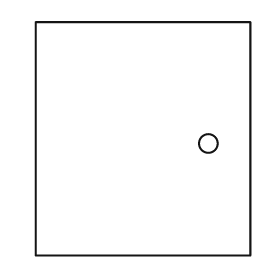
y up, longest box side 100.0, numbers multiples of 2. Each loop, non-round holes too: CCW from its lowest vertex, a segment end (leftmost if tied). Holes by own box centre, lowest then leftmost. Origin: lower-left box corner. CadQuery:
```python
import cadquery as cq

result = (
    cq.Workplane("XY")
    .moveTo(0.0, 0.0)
    .lineTo(92.0, 0.0)
    .lineTo(92.0, 100.0)
    .lineTo(0.0, 100.0)
    .close()
    .moveTo(74.0, 48.0)
    .circle(4.0)
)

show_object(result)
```